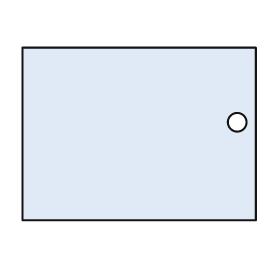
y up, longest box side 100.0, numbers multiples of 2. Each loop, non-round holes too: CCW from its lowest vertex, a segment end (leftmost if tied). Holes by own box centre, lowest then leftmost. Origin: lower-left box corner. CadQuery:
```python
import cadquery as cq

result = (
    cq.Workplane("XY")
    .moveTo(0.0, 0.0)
    .lineTo(100.0, 0.0)
    .lineTo(100.0, 74.0)
    .lineTo(0.0, 74.0)
    .close()
    .moveTo(92.0, 42.0)
    .circle(4.0)
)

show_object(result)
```